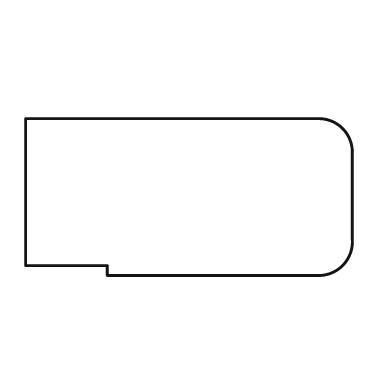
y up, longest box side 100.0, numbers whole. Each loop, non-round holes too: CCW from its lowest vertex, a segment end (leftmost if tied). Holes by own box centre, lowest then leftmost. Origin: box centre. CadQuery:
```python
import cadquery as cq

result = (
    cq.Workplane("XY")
    .moveTo(-25.0, -24.0)
    .lineTo(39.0, -24.0)
    .threePointArc((47.0, -21.0), (50.0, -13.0))
    .lineTo(50.0, 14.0)
    .threePointArc((47.0, 21.0), (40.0, 24.0))
    .lineTo(-50.0, 24.0)
    .lineTo(-50.0, -21.0)
    .lineTo(-25.0, -21.0)
    .close()
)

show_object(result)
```